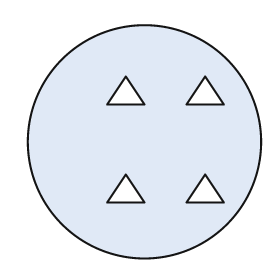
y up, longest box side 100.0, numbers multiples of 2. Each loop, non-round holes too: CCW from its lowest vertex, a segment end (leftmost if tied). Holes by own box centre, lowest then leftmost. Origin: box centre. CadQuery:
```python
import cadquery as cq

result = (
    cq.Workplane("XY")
    .moveTo(0.0, 0.0)
    .circle(50.0)
    .moveTo(-16.0, -26.0)
    .lineTo(0.0, -26.0)
    .lineTo(-8.0, -14.0)
    .close()
    .moveTo(18.0, -26.0)
    .lineTo(34.0, -26.0)
    .lineTo(26.0, -14.0)
    .close()
    .moveTo(-16.0, 16.0)
    .lineTo(0.0, 16.0)
    .lineTo(-8.0, 28.0)
    .close()
    .moveTo(18.0, 16.0)
    .lineTo(34.0, 16.0)
    .lineTo(26.0, 28.0)
    .close()
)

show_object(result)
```